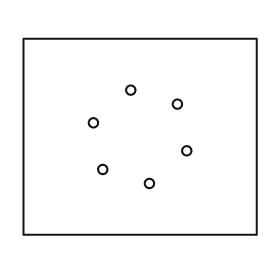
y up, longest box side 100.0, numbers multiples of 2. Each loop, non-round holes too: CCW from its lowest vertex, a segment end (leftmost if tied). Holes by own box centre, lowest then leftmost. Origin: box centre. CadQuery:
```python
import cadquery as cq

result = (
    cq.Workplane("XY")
    .moveTo(-50.0, -42.0)
    .lineTo(50.0, -42.0)
    .lineTo(50.0, 42.0)
    .lineTo(-50.0, 42.0)
    .close()
    .moveTo(4.0, -20.0)
    .circle(2.0)
    .moveTo(-16.0, -14.0)
    .circle(2.0)
    .moveTo(20.0, -6.0)
    .circle(2.0)
    .moveTo(-20.0, 6.0)
    .circle(2.0)
    .moveTo(16.0, 14.0)
    .circle(2.0)
    .moveTo(-4.0, 20.0)
    .circle(2.0)
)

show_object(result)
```